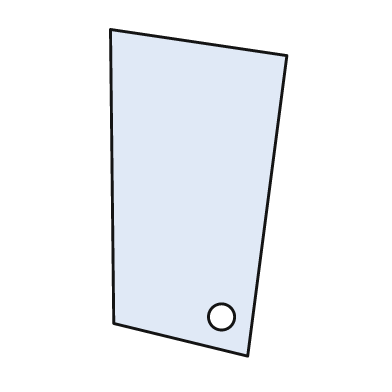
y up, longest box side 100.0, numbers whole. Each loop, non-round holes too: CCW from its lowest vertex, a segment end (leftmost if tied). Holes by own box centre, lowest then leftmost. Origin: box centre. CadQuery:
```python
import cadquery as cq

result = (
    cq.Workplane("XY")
    .moveTo(15.0, -50.0)
    .lineTo(27.0, 42.0)
    .lineTo(-27.0, 50.0)
    .lineTo(-26.0, -40.0)
    .close()
    .moveTo(7.0, -38.0)
    .circle(4.0)
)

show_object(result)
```